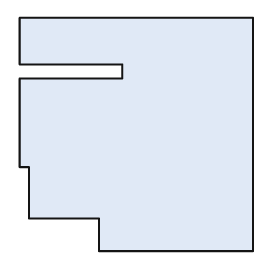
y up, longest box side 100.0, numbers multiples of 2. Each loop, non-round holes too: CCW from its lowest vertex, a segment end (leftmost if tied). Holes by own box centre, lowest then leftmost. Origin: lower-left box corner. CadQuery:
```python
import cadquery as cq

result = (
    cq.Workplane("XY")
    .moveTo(34.0, 0.0)
    .lineTo(100.0, 0.0)
    .lineTo(100.0, 100.0)
    .lineTo(0.0, 100.0)
    .lineTo(0.0, 80.0)
    .lineTo(44.0, 80.0)
    .lineTo(44.0, 74.0)
    .lineTo(0.0, 74.0)
    .lineTo(0.0, 36.0)
    .lineTo(4.0, 36.0)
    .lineTo(4.0, 14.0)
    .lineTo(34.0, 14.0)
    .close()
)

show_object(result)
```